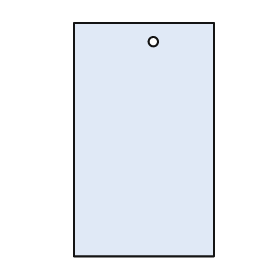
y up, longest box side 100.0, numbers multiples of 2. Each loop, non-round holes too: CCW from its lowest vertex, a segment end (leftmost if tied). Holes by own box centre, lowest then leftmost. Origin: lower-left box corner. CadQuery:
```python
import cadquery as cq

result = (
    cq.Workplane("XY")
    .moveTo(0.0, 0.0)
    .lineTo(60.0, 0.0)
    .lineTo(60.0, 100.0)
    .lineTo(0.0, 100.0)
    .close()
    .moveTo(34.0, 92.0)
    .circle(2.0)
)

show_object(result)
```